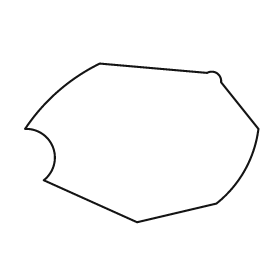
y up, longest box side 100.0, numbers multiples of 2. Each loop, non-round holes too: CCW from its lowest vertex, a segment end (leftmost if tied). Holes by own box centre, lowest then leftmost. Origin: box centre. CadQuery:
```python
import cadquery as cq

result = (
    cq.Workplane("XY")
    .moveTo(-2.0, -34.0)
    .lineTo(32.0, -26.0)
    .threePointArc((44.0, -12.0), (50.0, 6.0))
    .lineTo(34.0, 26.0)
    .threePointArc((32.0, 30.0), (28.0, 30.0))
    .lineTo(-18.0, 34.0)
    .threePointArc((-36.0, 22.0), (-50.0, 6.0))
    .threePointArc((-38.0, -2.0), (-42.0, -16.0))
    .close()
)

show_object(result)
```